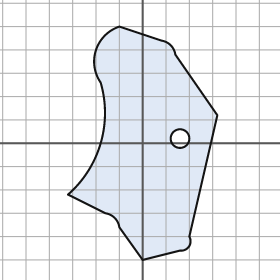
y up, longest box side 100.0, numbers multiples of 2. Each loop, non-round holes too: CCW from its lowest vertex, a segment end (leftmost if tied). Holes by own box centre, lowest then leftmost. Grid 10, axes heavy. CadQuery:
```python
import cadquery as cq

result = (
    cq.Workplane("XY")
    .moveTo(0.0, -50.0)
    .lineTo(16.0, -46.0)
    .threePointArc((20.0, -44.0), (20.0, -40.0))
    .lineTo(32.0, 12.0)
    .lineTo(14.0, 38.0)
    .threePointArc((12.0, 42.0), (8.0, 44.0))
    .lineTo(-10.0, 50.0)
    .threePointArc((-20.0, 40.0), (-18.0, 26.0))
    .threePointArc((-18.0, 0.0), (-32.0, -22.0))
    .lineTo(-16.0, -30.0)
    .threePointArc((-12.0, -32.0), (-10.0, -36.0))
    .close()
    .moveTo(16.0, 2.0)
    .circle(4.0)
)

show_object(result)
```